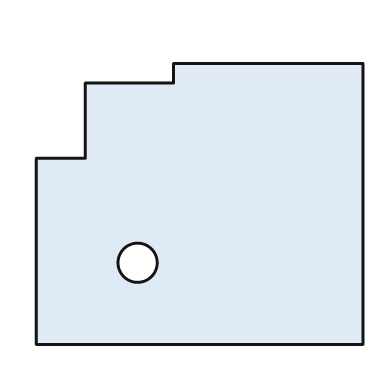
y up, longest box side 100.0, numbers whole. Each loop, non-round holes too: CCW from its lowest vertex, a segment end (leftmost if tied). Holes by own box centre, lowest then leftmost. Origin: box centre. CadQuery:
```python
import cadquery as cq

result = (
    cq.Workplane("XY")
    .moveTo(-50.0, -43.0)
    .lineTo(50.0, -43.0)
    .lineTo(50.0, 43.0)
    .lineTo(-8.0, 43.0)
    .lineTo(-8.0, 37.0)
    .lineTo(-35.0, 37.0)
    .lineTo(-35.0, 14.0)
    .lineTo(-50.0, 14.0)
    .close()
    .moveTo(-19.0, -18.0)
    .circle(6.0)
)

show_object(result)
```